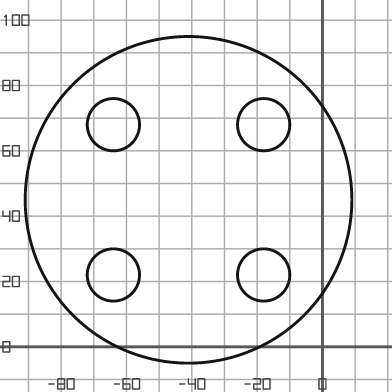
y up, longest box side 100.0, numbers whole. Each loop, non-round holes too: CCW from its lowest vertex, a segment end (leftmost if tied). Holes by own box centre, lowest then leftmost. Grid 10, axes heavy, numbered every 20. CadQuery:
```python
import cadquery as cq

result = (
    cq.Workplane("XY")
    .moveTo(-41.0, 45.0)
    .circle(50.0)
    .moveTo(-64.0, 22.0)
    .circle(8.0)
    .moveTo(-18.0, 22.0)
    .circle(8.0)
    .moveTo(-64.0, 68.0)
    .circle(8.0)
    .moveTo(-18.0, 68.0)
    .circle(8.0)
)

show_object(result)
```